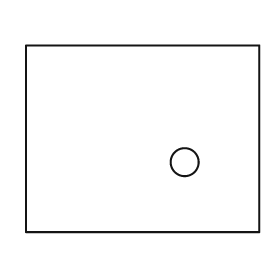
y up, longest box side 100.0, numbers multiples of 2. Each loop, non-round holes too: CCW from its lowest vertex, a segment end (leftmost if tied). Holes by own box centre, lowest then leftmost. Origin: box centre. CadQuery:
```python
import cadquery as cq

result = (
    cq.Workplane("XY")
    .moveTo(-50.0, -40.0)
    .lineTo(50.0, -40.0)
    .lineTo(50.0, 40.0)
    .lineTo(-50.0, 40.0)
    .close()
    .moveTo(18.0, -10.0)
    .circle(6.0)
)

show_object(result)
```